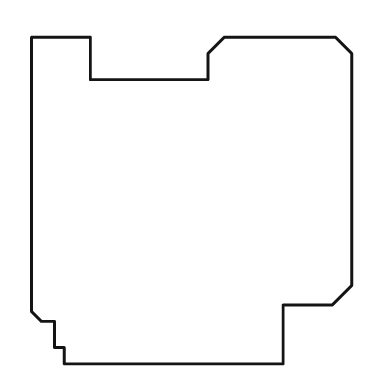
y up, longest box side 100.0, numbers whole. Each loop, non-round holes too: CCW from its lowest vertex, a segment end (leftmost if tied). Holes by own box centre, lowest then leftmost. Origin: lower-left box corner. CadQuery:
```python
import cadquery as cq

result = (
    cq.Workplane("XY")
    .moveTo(10.0, 0.0)
    .lineTo(77.0, 0.0)
    .lineTo(77.0, 18.0)
    .lineTo(92.0, 18.0)
    .lineTo(98.0, 24.0)
    .lineTo(98.0, 95.0)
    .lineTo(93.0, 100.0)
    .lineTo(59.0, 100.0)
    .lineTo(54.0, 95.0)
    .lineTo(54.0, 87.0)
    .lineTo(18.0, 87.0)
    .lineTo(18.0, 100.0)
    .lineTo(0.0, 100.0)
    .lineTo(0.0, 16.0)
    .lineTo(3.0, 13.0)
    .lineTo(7.0, 13.0)
    .lineTo(7.0, 5.0)
    .lineTo(10.0, 5.0)
    .close()
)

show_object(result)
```